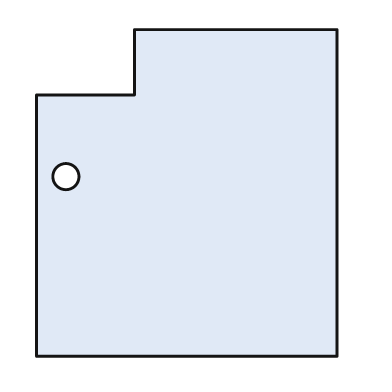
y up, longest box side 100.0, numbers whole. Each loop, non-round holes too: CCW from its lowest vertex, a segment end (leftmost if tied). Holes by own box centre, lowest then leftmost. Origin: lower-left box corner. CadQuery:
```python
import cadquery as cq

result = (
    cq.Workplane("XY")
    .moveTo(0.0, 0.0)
    .lineTo(92.0, 0.0)
    .lineTo(92.0, 100.0)
    .lineTo(30.0, 100.0)
    .lineTo(30.0, 80.0)
    .lineTo(0.0, 80.0)
    .close()
    .moveTo(9.0, 55.0)
    .circle(4.0)
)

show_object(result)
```